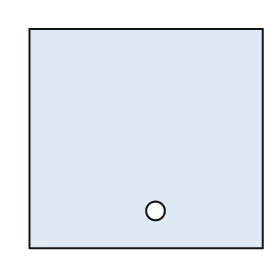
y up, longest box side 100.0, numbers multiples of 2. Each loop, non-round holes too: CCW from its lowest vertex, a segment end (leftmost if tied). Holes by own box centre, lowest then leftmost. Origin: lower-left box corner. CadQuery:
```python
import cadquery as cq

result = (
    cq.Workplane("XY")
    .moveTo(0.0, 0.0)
    .lineTo(100.0, 0.0)
    .lineTo(100.0, 94.0)
    .lineTo(0.0, 94.0)
    .close()
    .moveTo(54.0, 16.0)
    .circle(4.0)
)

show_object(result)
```